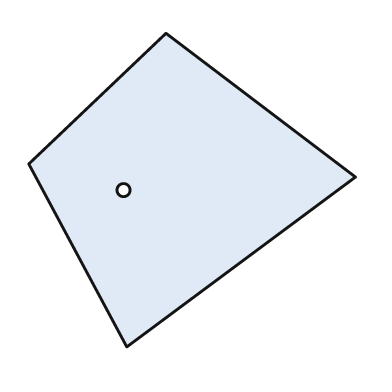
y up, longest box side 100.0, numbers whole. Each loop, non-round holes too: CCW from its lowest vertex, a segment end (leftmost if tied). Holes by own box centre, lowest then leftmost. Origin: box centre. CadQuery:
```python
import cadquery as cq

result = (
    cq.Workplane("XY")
    .moveTo(-20.0, -48.0)
    .lineTo(50.0, 4.0)
    .lineTo(-8.0, 48.0)
    .lineTo(-50.0, 8.0)
    .close()
    .moveTo(-21.0, 0.0)
    .circle(2.0)
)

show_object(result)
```